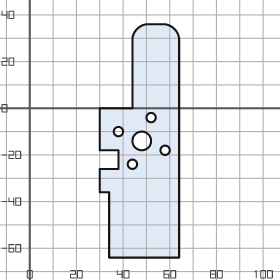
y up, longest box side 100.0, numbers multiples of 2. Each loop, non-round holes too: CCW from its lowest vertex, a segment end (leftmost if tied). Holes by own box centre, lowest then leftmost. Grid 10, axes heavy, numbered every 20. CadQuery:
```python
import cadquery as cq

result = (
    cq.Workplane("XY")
    .moveTo(34.0, -64.0)
    .lineTo(64.0, -64.0)
    .lineTo(64.0, 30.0)
    .threePointArc((62.0, 34.0), (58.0, 36.0))
    .lineTo(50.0, 36.0)
    .threePointArc((46.0, 34.0), (44.0, 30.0))
    .lineTo(44.0, 0.0)
    .lineTo(30.0, 0.0)
    .lineTo(30.0, -18.0)
    .lineTo(38.0, -18.0)
    .lineTo(38.0, -26.0)
    .lineTo(30.0, -26.0)
    .lineTo(30.0, -36.0)
    .lineTo(34.0, -36.0)
    .close()
    .moveTo(44.0, -24.0)
    .circle(2.0)
    .moveTo(58.0, -18.0)
    .circle(2.0)
    .moveTo(48.0, -14.0)
    .circle(4.0)
    .moveTo(38.0, -10.0)
    .circle(2.0)
    .moveTo(52.0, -4.0)
    .circle(2.0)
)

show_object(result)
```